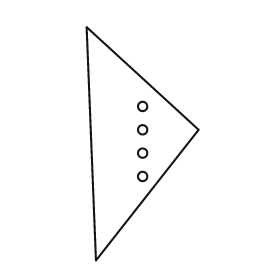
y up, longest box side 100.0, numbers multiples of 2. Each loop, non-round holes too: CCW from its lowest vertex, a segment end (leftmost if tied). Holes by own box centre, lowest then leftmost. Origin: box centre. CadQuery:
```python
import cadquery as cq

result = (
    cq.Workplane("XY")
    .moveTo(-20.0, -50.0)
    .lineTo(24.0, 6.0)
    .lineTo(-24.0, 50.0)
    .close()
    .moveTo(0.0, -14.0)
    .circle(2.0)
    .moveTo(0.0, -4.0)
    .circle(2.0)
    .moveTo(0.0, 6.0)
    .circle(2.0)
    .moveTo(0.0, 16.0)
    .circle(2.0)
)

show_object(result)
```